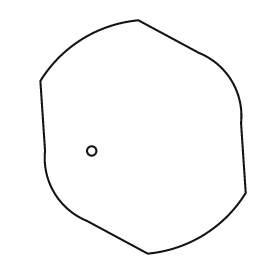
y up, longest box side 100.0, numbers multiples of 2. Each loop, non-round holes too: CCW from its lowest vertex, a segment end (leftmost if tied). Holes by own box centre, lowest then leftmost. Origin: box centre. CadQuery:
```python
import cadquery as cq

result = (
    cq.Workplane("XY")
    .moveTo(2.0, -50.0)
    .threePointArc((26.0, -42.0), (44.0, -24.0))
    .lineTo(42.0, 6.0)
    .threePointArc((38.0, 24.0), (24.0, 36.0))
    .lineTo(-2.0, 50.0)
    .threePointArc((-26.0, 42.0), (-44.0, 24.0))
    .lineTo(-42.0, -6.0)
    .threePointArc((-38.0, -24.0), (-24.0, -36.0))
    .close()
    .moveTo(-22.0, -6.0)
    .circle(2.0)
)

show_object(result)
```